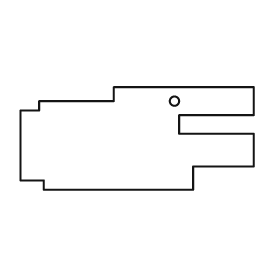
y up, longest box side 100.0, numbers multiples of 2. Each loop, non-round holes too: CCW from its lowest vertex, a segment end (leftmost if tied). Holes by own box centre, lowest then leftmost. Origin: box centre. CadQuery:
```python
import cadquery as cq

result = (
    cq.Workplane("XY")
    .moveTo(-40.0, -22.0)
    .lineTo(24.0, -22.0)
    .lineTo(24.0, -12.0)
    .lineTo(50.0, -12.0)
    .lineTo(50.0, 2.0)
    .lineTo(18.0, 2.0)
    .lineTo(18.0, 10.0)
    .lineTo(50.0, 10.0)
    .lineTo(50.0, 22.0)
    .lineTo(-10.0, 22.0)
    .lineTo(-10.0, 16.0)
    .lineTo(-42.0, 16.0)
    .lineTo(-42.0, 12.0)
    .lineTo(-50.0, 12.0)
    .lineTo(-50.0, -18.0)
    .lineTo(-40.0, -18.0)
    .close()
    .moveTo(16.0, 16.0)
    .circle(2.0)
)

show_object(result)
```